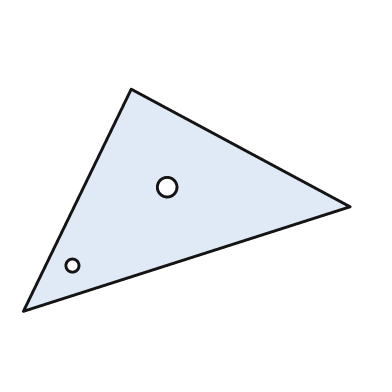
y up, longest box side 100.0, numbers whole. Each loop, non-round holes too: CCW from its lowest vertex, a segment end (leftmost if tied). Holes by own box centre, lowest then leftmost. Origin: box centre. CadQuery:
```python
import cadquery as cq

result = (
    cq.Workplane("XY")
    .moveTo(-50.0, -34.0)
    .lineTo(50.0, -2.0)
    .lineTo(-17.0, 34.0)
    .close()
    .moveTo(-35.0, -20.0)
    .circle(2.0)
    .moveTo(-6.0, 4.0)
    .circle(3.0)
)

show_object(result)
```